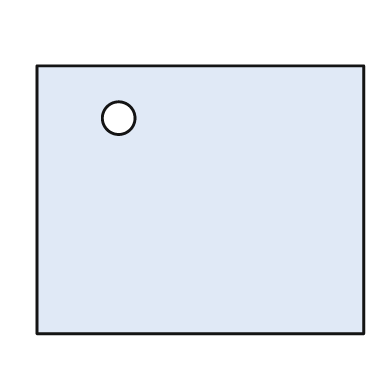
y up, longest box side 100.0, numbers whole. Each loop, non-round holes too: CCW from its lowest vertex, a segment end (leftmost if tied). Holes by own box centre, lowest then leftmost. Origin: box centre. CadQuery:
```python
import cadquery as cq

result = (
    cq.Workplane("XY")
    .moveTo(-50.0, -41.0)
    .lineTo(50.0, -41.0)
    .lineTo(50.0, 41.0)
    .lineTo(-50.0, 41.0)
    .close()
    .moveTo(-25.0, 25.0)
    .circle(5.0)
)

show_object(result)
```